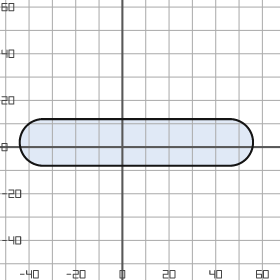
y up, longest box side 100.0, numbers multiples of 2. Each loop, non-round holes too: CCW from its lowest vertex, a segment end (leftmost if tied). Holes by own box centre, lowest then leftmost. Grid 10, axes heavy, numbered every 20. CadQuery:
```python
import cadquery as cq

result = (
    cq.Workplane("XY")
    .moveTo(-34.0, -8.0)
    .lineTo(46.0, -8.0)
    .threePointArc((56.0, 2.0), (46.0, 12.0))
    .lineTo(-34.0, 12.0)
    .threePointArc((-44.0, 2.0), (-34.0, -8.0))
    .close()
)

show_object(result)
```